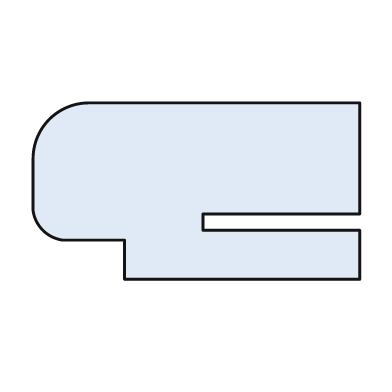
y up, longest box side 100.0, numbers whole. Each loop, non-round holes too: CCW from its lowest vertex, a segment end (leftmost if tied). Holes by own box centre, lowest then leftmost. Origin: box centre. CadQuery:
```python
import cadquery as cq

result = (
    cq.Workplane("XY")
    .moveTo(-22.0, -27.0)
    .lineTo(50.0, -27.0)
    .lineTo(50.0, -12.0)
    .lineTo(2.0, -12.0)
    .lineTo(2.0, -7.0)
    .lineTo(50.0, -7.0)
    .lineTo(50.0, 27.0)
    .lineTo(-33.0, 27.0)
    .threePointArc((-45.0, 22.0), (-50.0, 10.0))
    .lineTo(-50.0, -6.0)
    .threePointArc((-47.0, -12.0), (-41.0, -15.0))
    .lineTo(-22.0, -15.0)
    .close()
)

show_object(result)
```